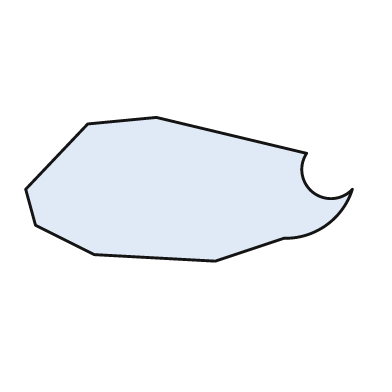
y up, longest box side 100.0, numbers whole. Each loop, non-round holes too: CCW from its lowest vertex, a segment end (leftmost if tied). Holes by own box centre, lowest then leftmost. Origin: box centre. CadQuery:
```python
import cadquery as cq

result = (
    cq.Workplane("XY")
    .moveTo(8.0, -22.0)
    .lineTo(29.0, -15.0)
    .threePointArc((42.0, -11.0), (50.0, 0.0))
    .threePointArc((38.0, -1.0), (36.0, 11.0))
    .lineTo(-10.0, 22.0)
    .lineTo(-31.0, 20.0)
    .lineTo(-50.0, 0.0)
    .lineTo(-47.0, -11.0)
    .lineTo(-29.0, -20.0)
    .close()
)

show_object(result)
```